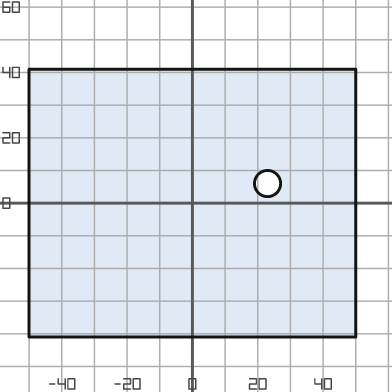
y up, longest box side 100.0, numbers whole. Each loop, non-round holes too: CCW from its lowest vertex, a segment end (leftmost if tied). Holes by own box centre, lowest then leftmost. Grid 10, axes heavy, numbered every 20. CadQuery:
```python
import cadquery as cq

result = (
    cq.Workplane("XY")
    .moveTo(-50.0, -41.0)
    .lineTo(50.0, -41.0)
    .lineTo(50.0, 41.0)
    .lineTo(-50.0, 41.0)
    .close()
    .moveTo(23.0, 6.0)
    .circle(4.0)
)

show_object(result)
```